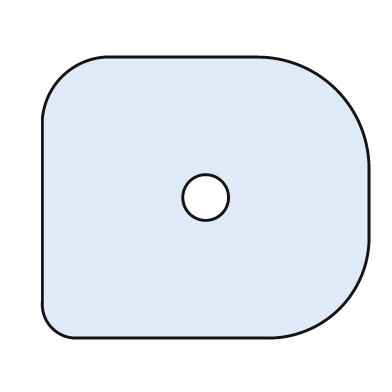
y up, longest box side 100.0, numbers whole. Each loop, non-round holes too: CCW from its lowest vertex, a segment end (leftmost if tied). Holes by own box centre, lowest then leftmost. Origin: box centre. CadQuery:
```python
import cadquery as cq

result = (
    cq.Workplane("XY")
    .moveTo(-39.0, -43.0)
    .lineTo(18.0, -43.0)
    .threePointArc((41.0, -34.0), (50.0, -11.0))
    .lineTo(50.0, 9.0)
    .threePointArc((40.0, 33.0), (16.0, 43.0))
    .lineTo(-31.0, 43.0)
    .threePointArc((-44.0, 37.0), (-50.0, 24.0))
    .lineTo(-50.0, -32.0)
    .threePointArc((-47.0, -40.0), (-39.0, -43.0))
    .close()
    .moveTo(0.0, 0.0)
    .circle(7.0)
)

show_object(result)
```